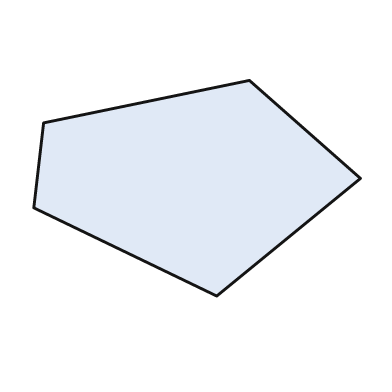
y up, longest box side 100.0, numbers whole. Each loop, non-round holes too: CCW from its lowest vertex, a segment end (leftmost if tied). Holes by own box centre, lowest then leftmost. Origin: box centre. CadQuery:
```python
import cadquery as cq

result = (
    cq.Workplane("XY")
    .moveTo(6.0, -33.0)
    .lineTo(50.0, 3.0)
    .lineTo(16.0, 33.0)
    .lineTo(-47.0, 20.0)
    .lineTo(-50.0, -6.0)
    .close()
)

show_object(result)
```